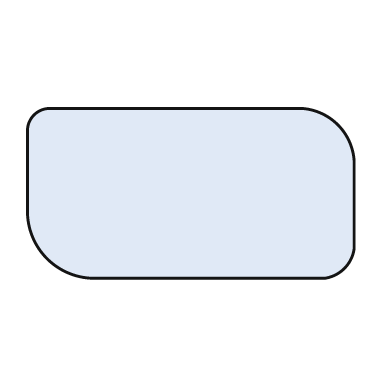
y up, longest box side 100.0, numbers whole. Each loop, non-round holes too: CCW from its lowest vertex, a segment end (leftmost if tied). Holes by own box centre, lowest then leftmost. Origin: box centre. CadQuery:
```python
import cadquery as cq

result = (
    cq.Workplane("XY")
    .moveTo(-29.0, -26.0)
    .lineTo(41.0, -26.0)
    .threePointArc((47.0, -23.0), (50.0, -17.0))
    .lineTo(50.0, 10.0)
    .threePointArc((45.0, 21.0), (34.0, 26.0))
    .lineTo(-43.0, 26.0)
    .threePointArc((-48.0, 24.0), (-50.0, 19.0))
    .lineTo(-50.0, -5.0)
    .threePointArc((-44.0, -20.0), (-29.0, -26.0))
    .close()
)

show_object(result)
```